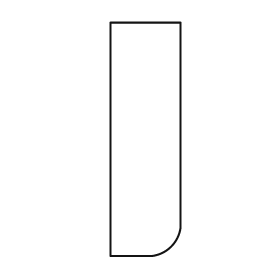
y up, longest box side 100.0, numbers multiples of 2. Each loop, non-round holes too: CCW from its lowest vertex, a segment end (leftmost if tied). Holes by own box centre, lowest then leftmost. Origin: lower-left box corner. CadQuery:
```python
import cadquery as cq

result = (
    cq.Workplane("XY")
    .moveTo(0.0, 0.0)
    .lineTo(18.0, 0.0)
    .threePointArc((26.0, 4.0), (30.0, 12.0))
    .lineTo(30.0, 100.0)
    .lineTo(0.0, 100.0)
    .close()
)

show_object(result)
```